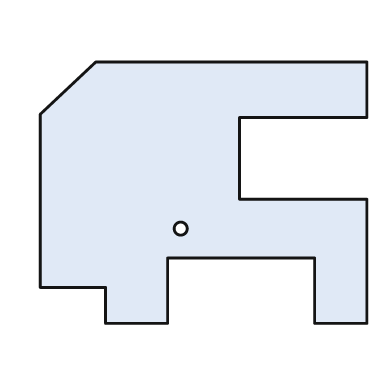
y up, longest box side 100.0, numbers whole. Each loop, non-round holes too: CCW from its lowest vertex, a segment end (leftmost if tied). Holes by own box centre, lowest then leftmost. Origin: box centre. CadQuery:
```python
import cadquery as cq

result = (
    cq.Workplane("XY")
    .moveTo(-30.0, -40.0)
    .lineTo(-11.0, -40.0)
    .lineTo(-11.0, -20.0)
    .lineTo(34.0, -20.0)
    .lineTo(34.0, -40.0)
    .lineTo(50.0, -40.0)
    .lineTo(50.0, -2.0)
    .lineTo(11.0, -2.0)
    .lineTo(11.0, 23.0)
    .lineTo(50.0, 23.0)
    .lineTo(50.0, 40.0)
    .lineTo(-33.0, 40.0)
    .lineTo(-50.0, 24.0)
    .lineTo(-50.0, -29.0)
    .lineTo(-30.0, -29.0)
    .close()
    .moveTo(-7.0, -11.0)
    .circle(2.0)
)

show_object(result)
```